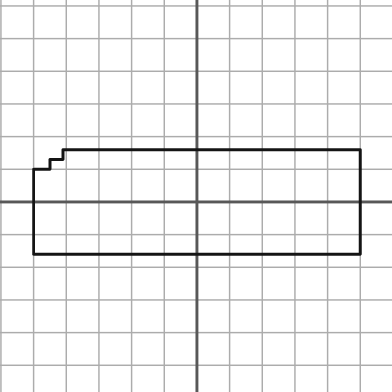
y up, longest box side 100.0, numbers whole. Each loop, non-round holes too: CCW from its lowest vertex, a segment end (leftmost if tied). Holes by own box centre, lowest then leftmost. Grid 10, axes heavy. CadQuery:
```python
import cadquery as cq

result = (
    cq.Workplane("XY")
    .moveTo(-50.0, -16.0)
    .lineTo(50.0, -16.0)
    .lineTo(50.0, 16.0)
    .lineTo(-41.0, 16.0)
    .lineTo(-41.0, 13.0)
    .lineTo(-45.0, 13.0)
    .lineTo(-45.0, 10.0)
    .lineTo(-50.0, 10.0)
    .close()
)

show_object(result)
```